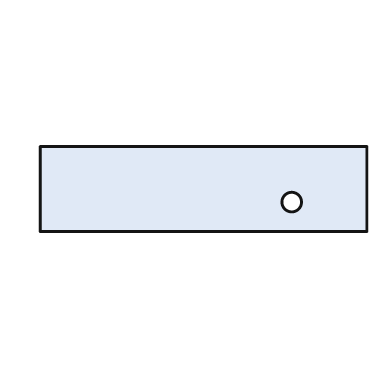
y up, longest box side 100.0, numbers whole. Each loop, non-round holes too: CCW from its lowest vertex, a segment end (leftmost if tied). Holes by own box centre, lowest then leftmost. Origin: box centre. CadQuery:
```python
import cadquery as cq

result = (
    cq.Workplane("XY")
    .moveTo(-50.0, -13.0)
    .lineTo(50.0, -13.0)
    .lineTo(50.0, 13.0)
    .lineTo(-50.0, 13.0)
    .close()
    .moveTo(27.0, -4.0)
    .circle(3.0)
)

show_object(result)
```